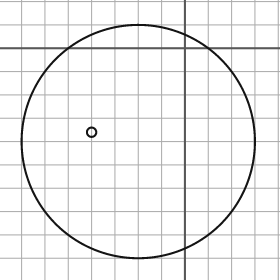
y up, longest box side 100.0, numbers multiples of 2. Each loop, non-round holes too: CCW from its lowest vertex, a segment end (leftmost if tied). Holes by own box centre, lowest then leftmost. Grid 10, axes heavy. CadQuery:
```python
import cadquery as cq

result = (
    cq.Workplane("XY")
    .moveTo(-20.0, -40.0)
    .circle(50.0)
    .moveTo(-40.0, -36.0)
    .circle(2.0)
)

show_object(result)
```